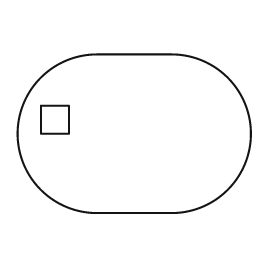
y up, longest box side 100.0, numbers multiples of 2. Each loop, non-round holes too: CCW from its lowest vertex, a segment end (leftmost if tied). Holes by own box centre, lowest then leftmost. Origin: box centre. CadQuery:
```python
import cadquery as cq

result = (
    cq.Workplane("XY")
    .moveTo(-16.0, -34.0)
    .lineTo(16.0, -34.0)
    .threePointArc((50.0, 0.0), (16.0, 34.0))
    .lineTo(-16.0, 34.0)
    .threePointArc((-50.0, 0.0), (-16.0, -34.0))
    .close()
    .moveTo(-40.0, 0.0)
    .lineTo(-28.0, 0.0)
    .lineTo(-28.0, 12.0)
    .lineTo(-40.0, 12.0)
    .close()
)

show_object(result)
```